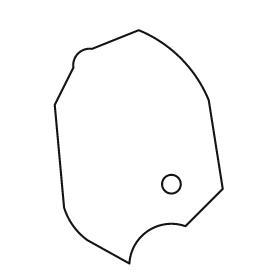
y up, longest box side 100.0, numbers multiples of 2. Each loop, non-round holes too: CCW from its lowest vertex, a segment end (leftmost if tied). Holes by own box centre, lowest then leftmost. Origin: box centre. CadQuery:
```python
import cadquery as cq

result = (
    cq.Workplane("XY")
    .moveTo(-4.0, -50.0)
    .threePointArc((4.0, -36.0), (20.0, -34.0))
    .lineTo(36.0, -18.0)
    .lineTo(30.0, 20.0)
    .threePointArc((18.0, 38.0), (0.0, 50.0))
    .lineTo(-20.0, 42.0)
    .threePointArc((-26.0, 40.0), (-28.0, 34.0))
    .lineTo(-36.0, 18.0)
    .lineTo(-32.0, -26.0)
    .threePointArc((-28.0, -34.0), (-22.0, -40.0))
    .close()
    .moveTo(14.0, -16.0)
    .circle(4.0)
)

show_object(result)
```